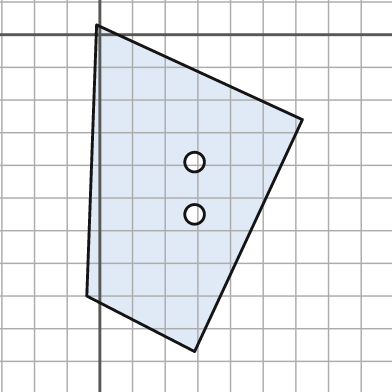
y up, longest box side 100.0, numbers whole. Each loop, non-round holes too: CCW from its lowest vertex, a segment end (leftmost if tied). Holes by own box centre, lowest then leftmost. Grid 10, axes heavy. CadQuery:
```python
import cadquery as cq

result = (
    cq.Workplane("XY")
    .moveTo(29.0, -97.0)
    .lineTo(62.0, -26.0)
    .lineTo(-1.0, 3.0)
    .lineTo(-4.0, -80.0)
    .close()
    .moveTo(29.0, -55.0)
    .circle(3.0)
    .moveTo(29.0, -39.0)
    .circle(3.0)
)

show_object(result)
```